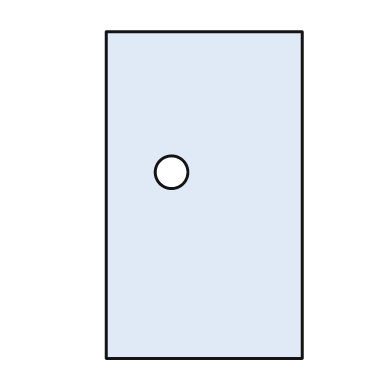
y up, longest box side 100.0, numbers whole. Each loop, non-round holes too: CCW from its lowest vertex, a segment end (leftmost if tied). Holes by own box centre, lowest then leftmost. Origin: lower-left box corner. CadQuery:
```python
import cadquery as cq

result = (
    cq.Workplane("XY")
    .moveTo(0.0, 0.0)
    .lineTo(60.0, 0.0)
    .lineTo(60.0, 100.0)
    .lineTo(0.0, 100.0)
    .close()
    .moveTo(20.0, 57.0)
    .circle(5.0)
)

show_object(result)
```